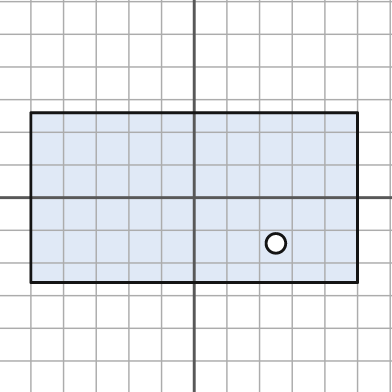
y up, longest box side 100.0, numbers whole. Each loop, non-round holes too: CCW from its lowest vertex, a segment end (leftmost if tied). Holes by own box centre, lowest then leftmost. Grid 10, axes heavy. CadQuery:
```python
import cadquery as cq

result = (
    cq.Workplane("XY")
    .moveTo(-50.0, -26.0)
    .lineTo(50.0, -26.0)
    .lineTo(50.0, 26.0)
    .lineTo(-50.0, 26.0)
    .close()
    .moveTo(25.0, -14.0)
    .circle(3.0)
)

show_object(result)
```